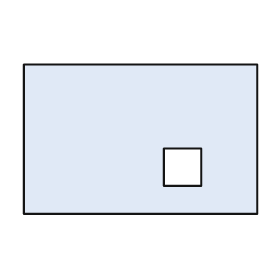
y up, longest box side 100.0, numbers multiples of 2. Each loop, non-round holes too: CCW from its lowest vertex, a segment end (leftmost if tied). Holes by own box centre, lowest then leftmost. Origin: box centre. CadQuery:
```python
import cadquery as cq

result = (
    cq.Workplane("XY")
    .moveTo(-50.0, -32.0)
    .lineTo(50.0, -32.0)
    .lineTo(50.0, 32.0)
    .lineTo(-50.0, 32.0)
    .close()
    .moveTo(10.0, -20.0)
    .lineTo(26.0, -20.0)
    .lineTo(26.0, -4.0)
    .lineTo(10.0, -4.0)
    .close()
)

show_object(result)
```